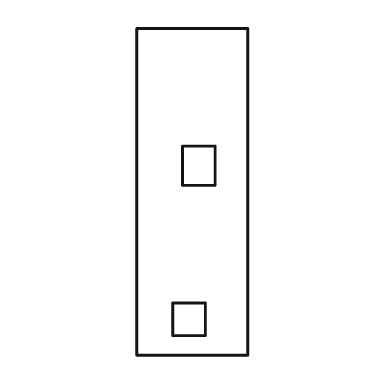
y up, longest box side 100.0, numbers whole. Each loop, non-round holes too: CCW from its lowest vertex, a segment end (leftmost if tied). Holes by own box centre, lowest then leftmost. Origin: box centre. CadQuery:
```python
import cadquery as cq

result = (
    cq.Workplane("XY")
    .moveTo(-17.0, -50.0)
    .lineTo(17.0, -50.0)
    .lineTo(17.0, 50.0)
    .lineTo(-17.0, 50.0)
    .close()
    .moveTo(-6.0, -44.0)
    .lineTo(4.0, -44.0)
    .lineTo(4.0, -34.0)
    .lineTo(-6.0, -34.0)
    .close()
    .moveTo(-3.0, 2.0)
    .lineTo(7.0, 2.0)
    .lineTo(7.0, 14.0)
    .lineTo(-3.0, 14.0)
    .close()
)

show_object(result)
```